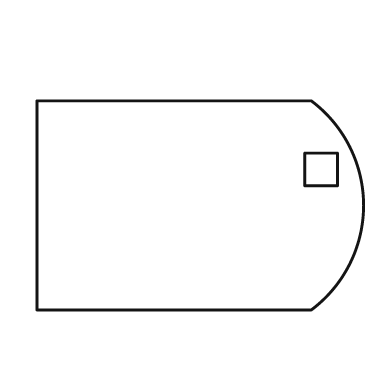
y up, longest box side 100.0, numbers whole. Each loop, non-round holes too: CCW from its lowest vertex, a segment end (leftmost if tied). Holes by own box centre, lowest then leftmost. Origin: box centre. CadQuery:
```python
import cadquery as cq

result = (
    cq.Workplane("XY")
    .moveTo(-50.0, -32.0)
    .lineTo(34.0, -32.0)
    .threePointArc((50.0, 0.0), (34.0, 32.0))
    .lineTo(-50.0, 32.0)
    .close()
    .moveTo(32.0, 6.0)
    .lineTo(42.0, 6.0)
    .lineTo(42.0, 16.0)
    .lineTo(32.0, 16.0)
    .close()
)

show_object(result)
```